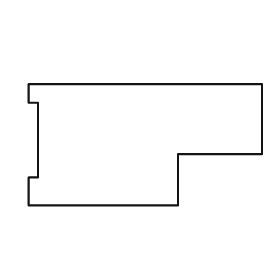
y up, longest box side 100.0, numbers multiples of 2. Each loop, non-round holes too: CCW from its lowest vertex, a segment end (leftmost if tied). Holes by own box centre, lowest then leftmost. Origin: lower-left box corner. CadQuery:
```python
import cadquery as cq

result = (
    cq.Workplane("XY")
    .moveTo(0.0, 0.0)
    .lineTo(64.0, 0.0)
    .lineTo(64.0, 22.0)
    .lineTo(100.0, 22.0)
    .lineTo(100.0, 52.0)
    .lineTo(0.0, 52.0)
    .lineTo(0.0, 44.0)
    .lineTo(4.0, 44.0)
    .lineTo(4.0, 12.0)
    .lineTo(0.0, 12.0)
    .close()
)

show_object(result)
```